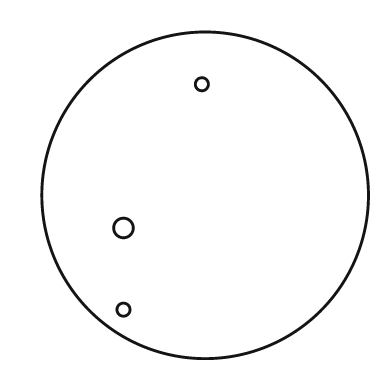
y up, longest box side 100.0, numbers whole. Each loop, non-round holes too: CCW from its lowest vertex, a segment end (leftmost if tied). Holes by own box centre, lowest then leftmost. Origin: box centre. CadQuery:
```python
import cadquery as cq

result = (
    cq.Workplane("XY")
    .moveTo(0.0, 0.0)
    .circle(50.0)
    .moveTo(-25.0, -35.0)
    .circle(2.0)
    .moveTo(-25.0, -10.0)
    .circle(3.0)
    .moveTo(-1.0, 34.0)
    .circle(2.0)
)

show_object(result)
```